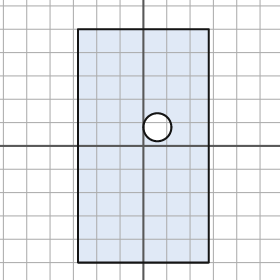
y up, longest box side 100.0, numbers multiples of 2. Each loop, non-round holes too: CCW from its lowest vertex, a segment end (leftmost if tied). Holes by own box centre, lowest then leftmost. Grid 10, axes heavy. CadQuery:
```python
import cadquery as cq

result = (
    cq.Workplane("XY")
    .moveTo(-28.0, -50.0)
    .lineTo(28.0, -50.0)
    .lineTo(28.0, 50.0)
    .lineTo(-28.0, 50.0)
    .close()
    .moveTo(6.0, 8.0)
    .circle(6.0)
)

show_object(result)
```